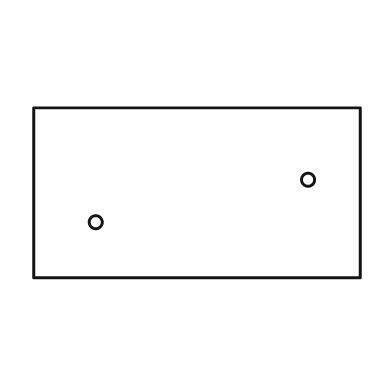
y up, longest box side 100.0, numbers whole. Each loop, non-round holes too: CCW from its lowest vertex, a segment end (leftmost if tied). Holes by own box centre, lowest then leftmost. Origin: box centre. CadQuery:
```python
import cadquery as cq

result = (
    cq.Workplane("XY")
    .moveTo(-50.0, -26.0)
    .lineTo(50.0, -26.0)
    .lineTo(50.0, 26.0)
    .lineTo(-50.0, 26.0)
    .close()
    .moveTo(-31.0, -9.0)
    .circle(2.0)
    .moveTo(34.0, 4.0)
    .circle(2.0)
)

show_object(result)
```